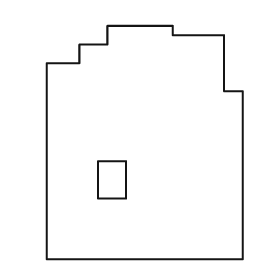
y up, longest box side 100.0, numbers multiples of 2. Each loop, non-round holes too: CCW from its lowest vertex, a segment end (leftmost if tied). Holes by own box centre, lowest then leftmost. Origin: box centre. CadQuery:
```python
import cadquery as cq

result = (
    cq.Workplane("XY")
    .moveTo(-42.0, -50.0)
    .lineTo(42.0, -50.0)
    .lineTo(42.0, 22.0)
    .lineTo(34.0, 22.0)
    .lineTo(34.0, 46.0)
    .lineTo(12.0, 46.0)
    .lineTo(12.0, 50.0)
    .lineTo(-16.0, 50.0)
    .lineTo(-16.0, 42.0)
    .lineTo(-28.0, 42.0)
    .lineTo(-28.0, 34.0)
    .lineTo(-42.0, 34.0)
    .close()
    .moveTo(-20.0, -24.0)
    .lineTo(-8.0, -24.0)
    .lineTo(-8.0, -8.0)
    .lineTo(-20.0, -8.0)
    .close()
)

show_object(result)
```